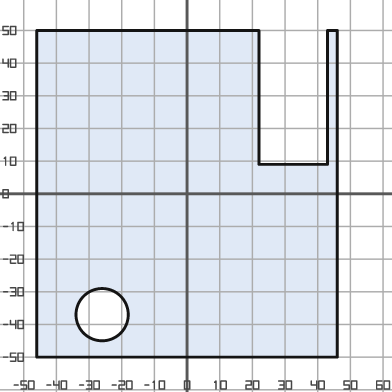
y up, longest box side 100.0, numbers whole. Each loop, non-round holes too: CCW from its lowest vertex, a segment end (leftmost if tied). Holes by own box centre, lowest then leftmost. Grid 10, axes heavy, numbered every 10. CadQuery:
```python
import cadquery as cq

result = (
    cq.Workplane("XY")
    .moveTo(-46.0, -50.0)
    .lineTo(46.0, -50.0)
    .lineTo(46.0, 50.0)
    .lineTo(43.0, 50.0)
    .lineTo(43.0, 9.0)
    .lineTo(22.0, 9.0)
    .lineTo(22.0, 50.0)
    .lineTo(-46.0, 50.0)
    .close()
    .moveTo(-26.0, -37.0)
    .circle(8.0)
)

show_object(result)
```